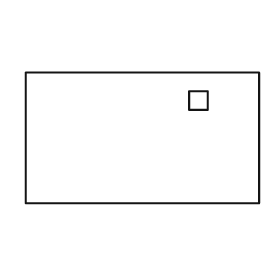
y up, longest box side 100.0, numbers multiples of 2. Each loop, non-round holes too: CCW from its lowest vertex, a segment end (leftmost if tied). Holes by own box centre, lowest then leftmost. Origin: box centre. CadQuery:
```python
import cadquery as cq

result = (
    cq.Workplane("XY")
    .moveTo(-50.0, -28.0)
    .lineTo(50.0, -28.0)
    .lineTo(50.0, 28.0)
    .lineTo(-50.0, 28.0)
    .close()
    .moveTo(20.0, 12.0)
    .lineTo(28.0, 12.0)
    .lineTo(28.0, 20.0)
    .lineTo(20.0, 20.0)
    .close()
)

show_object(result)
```